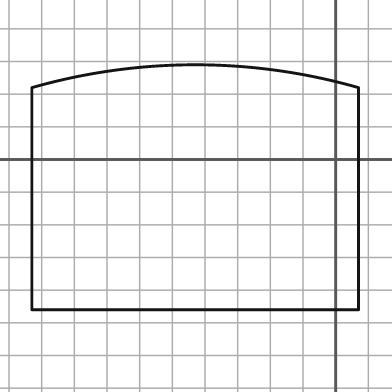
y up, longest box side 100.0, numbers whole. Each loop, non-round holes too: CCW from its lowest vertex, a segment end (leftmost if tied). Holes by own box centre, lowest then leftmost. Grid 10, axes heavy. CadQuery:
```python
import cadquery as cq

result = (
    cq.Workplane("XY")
    .moveTo(-93.0, -46.0)
    .lineTo(7.0, -46.0)
    .lineTo(7.0, 22.0)
    .threePointArc((-43.0, 29.0), (-93.0, 22.0))
    .close()
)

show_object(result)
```